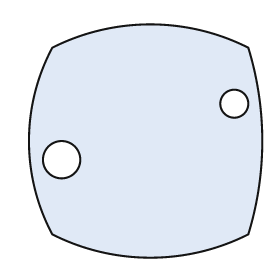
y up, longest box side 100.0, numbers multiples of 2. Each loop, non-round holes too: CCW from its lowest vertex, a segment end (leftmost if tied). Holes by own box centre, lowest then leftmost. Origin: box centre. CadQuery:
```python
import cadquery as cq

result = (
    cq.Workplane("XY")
    .moveTo(-40.0, -40.0)
    .threePointArc((2.0, -50.0), (44.0, -40.0))
    .threePointArc((50.0, 0.0), (44.0, 40.0))
    .threePointArc((2.0, 50.0), (-40.0, 40.0))
    .threePointArc((-50.0, 0.0), (-40.0, -40.0))
    .close()
    .moveTo(-36.0, -8.0)
    .circle(8.0)
    .moveTo(38.0, 16.0)
    .circle(6.0)
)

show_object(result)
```